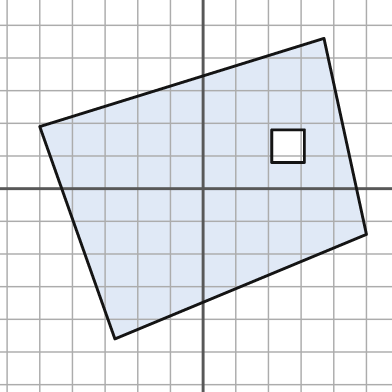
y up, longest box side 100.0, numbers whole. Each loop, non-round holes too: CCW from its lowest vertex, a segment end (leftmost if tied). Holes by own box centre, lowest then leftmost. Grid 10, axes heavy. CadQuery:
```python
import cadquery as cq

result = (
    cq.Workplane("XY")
    .moveTo(-27.0, -46.0)
    .lineTo(50.0, -14.0)
    .lineTo(37.0, 46.0)
    .lineTo(-50.0, 19.0)
    .close()
    .moveTo(21.0, 8.0)
    .lineTo(31.0, 8.0)
    .lineTo(31.0, 18.0)
    .lineTo(21.0, 18.0)
    .close()
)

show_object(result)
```